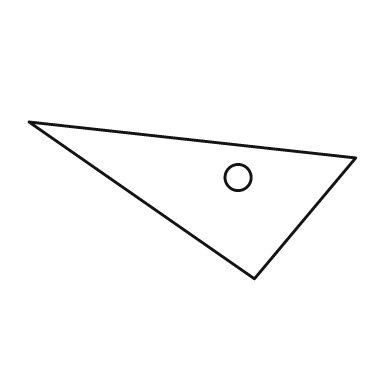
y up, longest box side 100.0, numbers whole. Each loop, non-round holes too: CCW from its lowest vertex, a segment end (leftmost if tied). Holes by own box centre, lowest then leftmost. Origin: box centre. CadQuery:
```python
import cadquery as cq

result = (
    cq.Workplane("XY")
    .moveTo(19.0, -24.0)
    .lineTo(50.0, 13.0)
    .lineTo(-50.0, 24.0)
    .close()
    .moveTo(14.0, 7.0)
    .circle(4.0)
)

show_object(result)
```